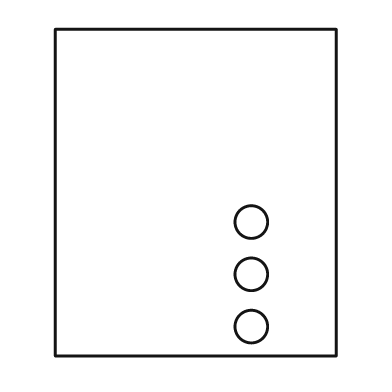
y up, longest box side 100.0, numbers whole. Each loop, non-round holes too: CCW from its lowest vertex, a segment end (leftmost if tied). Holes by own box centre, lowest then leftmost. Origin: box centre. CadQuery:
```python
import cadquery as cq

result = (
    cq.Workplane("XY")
    .moveTo(-43.0, -50.0)
    .lineTo(43.0, -50.0)
    .lineTo(43.0, 50.0)
    .lineTo(-43.0, 50.0)
    .close()
    .moveTo(17.0, -41.0)
    .circle(5.0)
    .moveTo(17.0, -25.0)
    .circle(5.0)
    .moveTo(17.0, -9.0)
    .circle(5.0)
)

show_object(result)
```